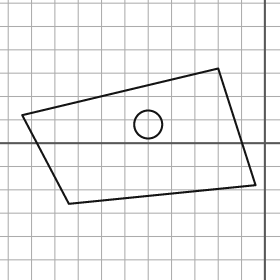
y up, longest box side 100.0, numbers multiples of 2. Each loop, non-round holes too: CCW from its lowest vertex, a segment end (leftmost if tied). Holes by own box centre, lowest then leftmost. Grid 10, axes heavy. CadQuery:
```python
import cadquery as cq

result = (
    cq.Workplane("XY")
    .moveTo(-84.0, -26.0)
    .lineTo(-4.0, -18.0)
    .lineTo(-20.0, 32.0)
    .lineTo(-104.0, 12.0)
    .close()
    .moveTo(-50.0, 8.0)
    .circle(6.0)
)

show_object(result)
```